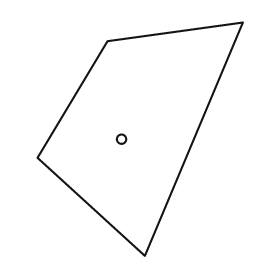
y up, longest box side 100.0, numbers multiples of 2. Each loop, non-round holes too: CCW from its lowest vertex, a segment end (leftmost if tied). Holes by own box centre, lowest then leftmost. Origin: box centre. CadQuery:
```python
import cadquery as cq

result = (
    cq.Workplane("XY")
    .moveTo(2.0, -50.0)
    .lineTo(44.0, 50.0)
    .lineTo(-14.0, 42.0)
    .lineTo(-44.0, -8.0)
    .close()
    .moveTo(-8.0, 0.0)
    .circle(2.0)
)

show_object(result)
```